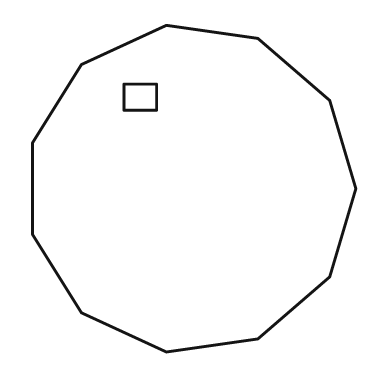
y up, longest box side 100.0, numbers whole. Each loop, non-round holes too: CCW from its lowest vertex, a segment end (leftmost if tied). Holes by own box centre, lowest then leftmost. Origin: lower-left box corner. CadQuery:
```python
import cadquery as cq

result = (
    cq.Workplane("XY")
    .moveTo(41.0, 0.0)
    .lineTo(69.0, 4.0)
    .lineTo(91.0, 23.0)
    .lineTo(99.0, 50.0)
    .lineTo(91.0, 77.0)
    .lineTo(69.0, 96.0)
    .lineTo(41.0, 100.0)
    .lineTo(15.0, 88.0)
    .lineTo(0.0, 64.0)
    .lineTo(0.0, 36.0)
    .lineTo(15.0, 12.0)
    .close()
    .moveTo(28.0, 74.0)
    .lineTo(38.0, 74.0)
    .lineTo(38.0, 82.0)
    .lineTo(28.0, 82.0)
    .close()
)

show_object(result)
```